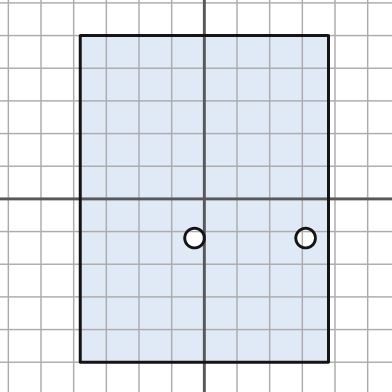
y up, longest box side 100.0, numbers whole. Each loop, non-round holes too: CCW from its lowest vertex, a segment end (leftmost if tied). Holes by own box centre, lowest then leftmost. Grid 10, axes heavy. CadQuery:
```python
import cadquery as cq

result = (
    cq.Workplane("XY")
    .moveTo(-38.0, -50.0)
    .lineTo(38.0, -50.0)
    .lineTo(38.0, 50.0)
    .lineTo(-38.0, 50.0)
    .close()
    .moveTo(-3.0, -12.0)
    .circle(3.0)
    .moveTo(31.0, -12.0)
    .circle(3.0)
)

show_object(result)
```